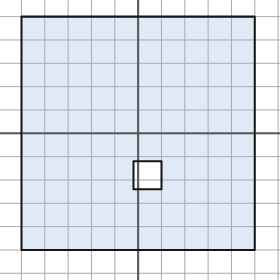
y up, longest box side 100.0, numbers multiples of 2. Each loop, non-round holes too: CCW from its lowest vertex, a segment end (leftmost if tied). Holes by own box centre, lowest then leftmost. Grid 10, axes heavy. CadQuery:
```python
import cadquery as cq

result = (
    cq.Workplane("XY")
    .moveTo(-50.0, -50.0)
    .lineTo(50.0, -50.0)
    .lineTo(50.0, 50.0)
    .lineTo(-50.0, 50.0)
    .close()
    .moveTo(-2.0, -24.0)
    .lineTo(10.0, -24.0)
    .lineTo(10.0, -12.0)
    .lineTo(-2.0, -12.0)
    .close()
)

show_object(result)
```